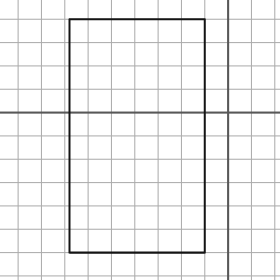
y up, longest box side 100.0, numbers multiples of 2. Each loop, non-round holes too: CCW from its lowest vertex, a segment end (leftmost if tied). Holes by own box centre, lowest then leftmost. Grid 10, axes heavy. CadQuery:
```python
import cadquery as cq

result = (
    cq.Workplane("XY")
    .moveTo(-68.0, -60.0)
    .lineTo(-10.0, -60.0)
    .lineTo(-10.0, 40.0)
    .lineTo(-68.0, 40.0)
    .close()
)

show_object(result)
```